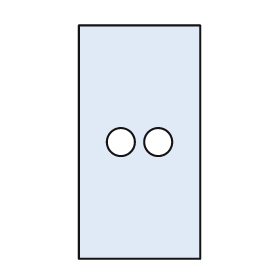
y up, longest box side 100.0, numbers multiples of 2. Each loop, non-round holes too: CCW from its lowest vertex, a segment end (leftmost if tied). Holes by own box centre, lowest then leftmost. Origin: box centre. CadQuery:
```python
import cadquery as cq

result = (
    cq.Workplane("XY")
    .moveTo(-26.0, -50.0)
    .lineTo(26.0, -50.0)
    .lineTo(26.0, 50.0)
    .lineTo(-26.0, 50.0)
    .close()
    .moveTo(-8.0, 0.0)
    .circle(6.0)
    .moveTo(8.0, 0.0)
    .circle(6.0)
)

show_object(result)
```